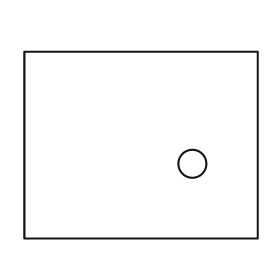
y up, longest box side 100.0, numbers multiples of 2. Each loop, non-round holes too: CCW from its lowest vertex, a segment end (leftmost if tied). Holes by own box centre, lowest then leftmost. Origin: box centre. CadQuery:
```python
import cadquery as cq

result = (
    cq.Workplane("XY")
    .moveTo(-50.0, -40.0)
    .lineTo(50.0, -40.0)
    .lineTo(50.0, 40.0)
    .lineTo(-50.0, 40.0)
    .close()
    .moveTo(22.0, -8.0)
    .circle(6.0)
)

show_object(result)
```